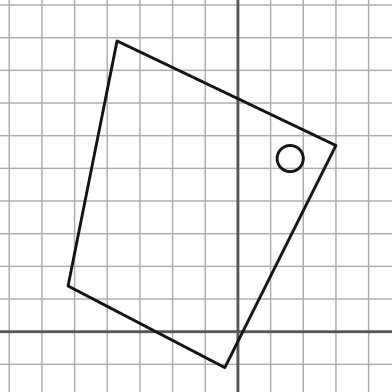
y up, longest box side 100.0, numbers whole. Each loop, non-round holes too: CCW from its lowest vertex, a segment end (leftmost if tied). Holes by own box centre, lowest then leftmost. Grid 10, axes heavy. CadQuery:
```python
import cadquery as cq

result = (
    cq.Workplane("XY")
    .moveTo(-4.0, -11.0)
    .lineTo(30.0, 57.0)
    .lineTo(-37.0, 89.0)
    .lineTo(-52.0, 14.0)
    .close()
    .moveTo(16.0, 53.0)
    .circle(4.0)
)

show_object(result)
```